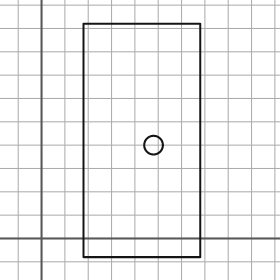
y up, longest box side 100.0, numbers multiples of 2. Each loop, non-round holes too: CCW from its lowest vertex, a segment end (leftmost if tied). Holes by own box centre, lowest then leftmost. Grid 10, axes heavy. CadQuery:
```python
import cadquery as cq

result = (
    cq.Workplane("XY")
    .moveTo(18.0, -8.0)
    .lineTo(68.0, -8.0)
    .lineTo(68.0, 92.0)
    .lineTo(18.0, 92.0)
    .close()
    .moveTo(48.0, 40.0)
    .circle(4.0)
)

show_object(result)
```